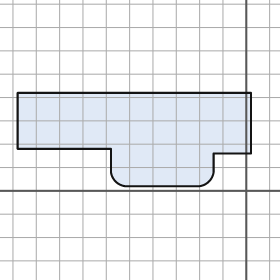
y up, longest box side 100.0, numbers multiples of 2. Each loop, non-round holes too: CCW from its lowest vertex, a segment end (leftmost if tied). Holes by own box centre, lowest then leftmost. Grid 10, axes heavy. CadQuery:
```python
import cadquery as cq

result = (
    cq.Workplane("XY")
    .moveTo(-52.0, 2.0)
    .lineTo(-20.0, 2.0)
    .threePointArc((-16.0, 4.0), (-14.0, 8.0))
    .lineTo(-14.0, 16.0)
    .lineTo(2.0, 16.0)
    .lineTo(2.0, 42.0)
    .lineTo(-98.0, 42.0)
    .lineTo(-98.0, 18.0)
    .lineTo(-58.0, 18.0)
    .lineTo(-58.0, 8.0)
    .threePointArc((-56.0, 4.0), (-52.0, 2.0))
    .close()
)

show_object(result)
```